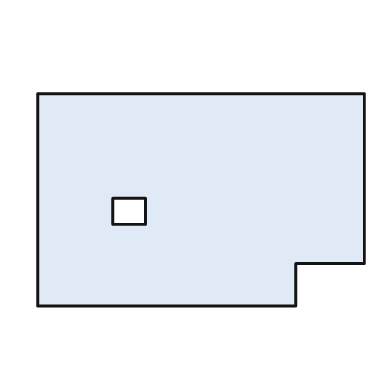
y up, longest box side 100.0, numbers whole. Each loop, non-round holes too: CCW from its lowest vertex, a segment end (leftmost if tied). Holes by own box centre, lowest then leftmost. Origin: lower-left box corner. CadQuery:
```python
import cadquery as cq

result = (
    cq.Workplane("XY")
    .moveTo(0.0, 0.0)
    .lineTo(79.0, 0.0)
    .lineTo(79.0, 13.0)
    .lineTo(100.0, 13.0)
    .lineTo(100.0, 65.0)
    .lineTo(0.0, 65.0)
    .close()
    .moveTo(23.0, 25.0)
    .lineTo(33.0, 25.0)
    .lineTo(33.0, 33.0)
    .lineTo(23.0, 33.0)
    .close()
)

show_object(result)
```